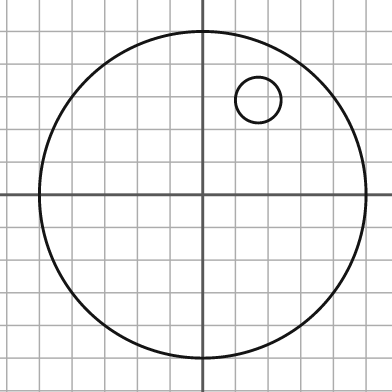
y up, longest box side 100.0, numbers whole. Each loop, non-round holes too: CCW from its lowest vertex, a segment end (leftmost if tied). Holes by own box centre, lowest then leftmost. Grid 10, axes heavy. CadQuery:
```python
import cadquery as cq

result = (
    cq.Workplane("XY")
    .moveTo(0.0, 0.0)
    .circle(50.0)
    .moveTo(17.0, 29.0)
    .circle(7.0)
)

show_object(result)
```